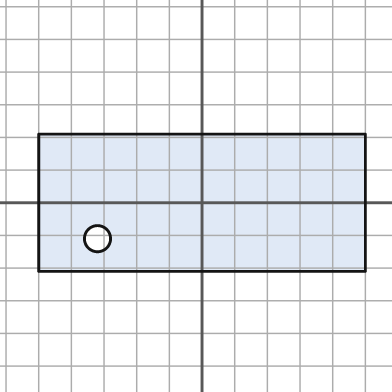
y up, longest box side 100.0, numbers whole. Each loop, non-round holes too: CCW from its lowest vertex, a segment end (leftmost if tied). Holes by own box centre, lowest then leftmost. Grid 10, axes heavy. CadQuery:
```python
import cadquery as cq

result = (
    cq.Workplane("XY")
    .moveTo(-50.0, -21.0)
    .lineTo(50.0, -21.0)
    .lineTo(50.0, 21.0)
    .lineTo(-50.0, 21.0)
    .close()
    .moveTo(-32.0, -11.0)
    .circle(4.0)
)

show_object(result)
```